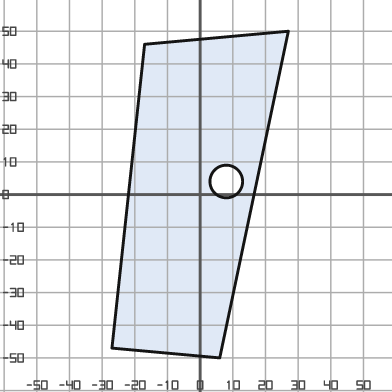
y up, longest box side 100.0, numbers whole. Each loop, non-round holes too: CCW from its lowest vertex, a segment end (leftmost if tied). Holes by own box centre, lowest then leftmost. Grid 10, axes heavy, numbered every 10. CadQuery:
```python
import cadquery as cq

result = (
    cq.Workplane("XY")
    .moveTo(6.0, -50.0)
    .lineTo(27.0, 50.0)
    .lineTo(-17.0, 46.0)
    .lineTo(-27.0, -47.0)
    .close()
    .moveTo(8.0, 4.0)
    .circle(5.0)
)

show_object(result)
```